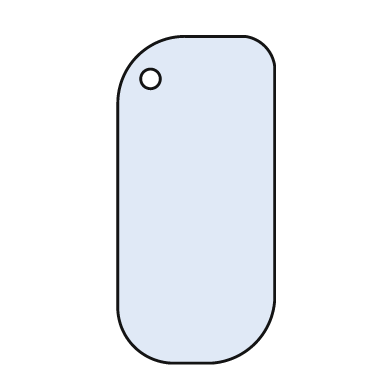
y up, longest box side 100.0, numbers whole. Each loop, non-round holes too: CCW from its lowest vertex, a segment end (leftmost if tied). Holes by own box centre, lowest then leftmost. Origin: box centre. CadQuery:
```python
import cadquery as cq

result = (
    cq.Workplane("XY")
    .moveTo(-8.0, -50.0)
    .lineTo(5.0, -50.0)
    .threePointArc((18.0, -44.0), (24.0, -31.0))
    .lineTo(24.0, 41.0)
    .threePointArc((21.0, 47.0), (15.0, 50.0))
    .lineTo(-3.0, 50.0)
    .threePointArc((-18.0, 44.0), (-24.0, 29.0))
    .lineTo(-24.0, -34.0)
    .threePointArc((-19.0, -45.0), (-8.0, -50.0))
    .close()
    .moveTo(-14.0, 37.0)
    .circle(3.0)
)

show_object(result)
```